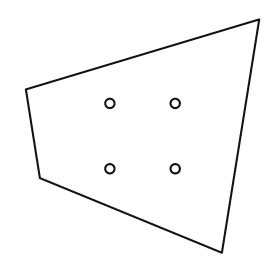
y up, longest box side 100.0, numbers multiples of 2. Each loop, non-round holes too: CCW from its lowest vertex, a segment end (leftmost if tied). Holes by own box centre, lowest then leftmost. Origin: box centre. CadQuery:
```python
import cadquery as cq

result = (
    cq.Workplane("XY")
    .moveTo(34.0, -50.0)
    .lineTo(50.0, 50.0)
    .lineTo(-50.0, 20.0)
    .lineTo(-44.0, -18.0)
    .close()
    .moveTo(-14.0, -14.0)
    .circle(2.0)
    .moveTo(14.0, -14.0)
    .circle(2.0)
    .moveTo(-14.0, 14.0)
    .circle(2.0)
    .moveTo(14.0, 14.0)
    .circle(2.0)
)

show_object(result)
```